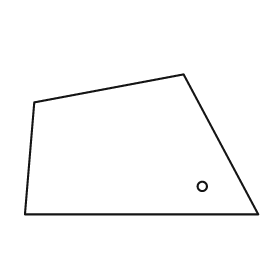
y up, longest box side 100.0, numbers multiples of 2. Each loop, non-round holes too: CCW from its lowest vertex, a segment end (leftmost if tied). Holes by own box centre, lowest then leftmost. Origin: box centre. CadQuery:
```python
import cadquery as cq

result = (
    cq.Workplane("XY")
    .moveTo(-50.0, -30.0)
    .lineTo(50.0, -30.0)
    .lineTo(18.0, 30.0)
    .lineTo(-46.0, 18.0)
    .close()
    .moveTo(26.0, -18.0)
    .circle(2.0)
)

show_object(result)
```